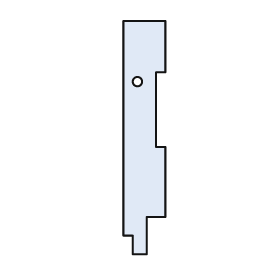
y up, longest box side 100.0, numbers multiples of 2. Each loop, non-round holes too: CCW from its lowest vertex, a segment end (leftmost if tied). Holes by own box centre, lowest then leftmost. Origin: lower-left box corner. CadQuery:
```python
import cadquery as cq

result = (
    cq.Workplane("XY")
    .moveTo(4.0, 0.0)
    .lineTo(10.0, 0.0)
    .lineTo(10.0, 16.0)
    .lineTo(18.0, 16.0)
    .lineTo(18.0, 46.0)
    .lineTo(14.0, 46.0)
    .lineTo(14.0, 78.0)
    .lineTo(18.0, 78.0)
    .lineTo(18.0, 100.0)
    .lineTo(0.0, 100.0)
    .lineTo(0.0, 8.0)
    .lineTo(4.0, 8.0)
    .close()
    .moveTo(6.0, 74.0)
    .circle(2.0)
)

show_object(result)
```